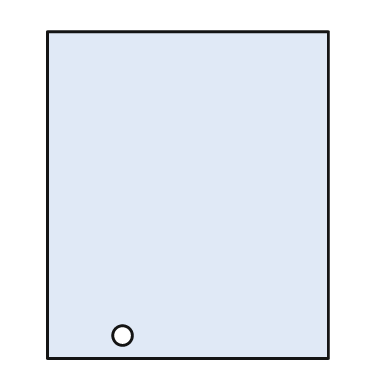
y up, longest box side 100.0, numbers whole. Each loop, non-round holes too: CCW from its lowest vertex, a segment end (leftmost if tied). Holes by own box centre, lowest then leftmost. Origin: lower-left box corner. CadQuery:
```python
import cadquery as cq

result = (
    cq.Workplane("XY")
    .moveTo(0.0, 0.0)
    .lineTo(86.0, 0.0)
    .lineTo(86.0, 100.0)
    .lineTo(0.0, 100.0)
    .close()
    .moveTo(23.0, 7.0)
    .circle(3.0)
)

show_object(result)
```